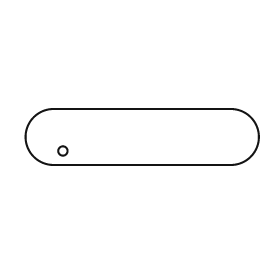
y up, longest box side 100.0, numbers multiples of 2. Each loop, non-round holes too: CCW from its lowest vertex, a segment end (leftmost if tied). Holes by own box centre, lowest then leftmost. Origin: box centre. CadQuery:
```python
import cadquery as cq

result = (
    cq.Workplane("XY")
    .moveTo(-38.0, -12.0)
    .lineTo(38.0, -12.0)
    .threePointArc((50.0, 0.0), (38.0, 12.0))
    .lineTo(-38.0, 12.0)
    .threePointArc((-50.0, 0.0), (-38.0, -12.0))
    .close()
    .moveTo(-34.0, -6.0)
    .circle(2.0)
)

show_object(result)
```